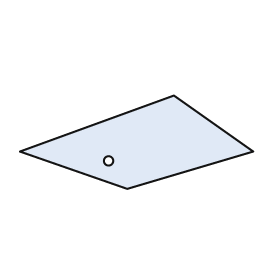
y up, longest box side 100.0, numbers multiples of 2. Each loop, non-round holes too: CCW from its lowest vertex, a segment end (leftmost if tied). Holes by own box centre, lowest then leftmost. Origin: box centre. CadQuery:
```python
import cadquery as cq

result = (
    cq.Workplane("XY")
    .moveTo(-4.0, -20.0)
    .lineTo(50.0, -4.0)
    .lineTo(16.0, 20.0)
    .lineTo(-50.0, -4.0)
    .close()
    .moveTo(-12.0, -8.0)
    .circle(2.0)
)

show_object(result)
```